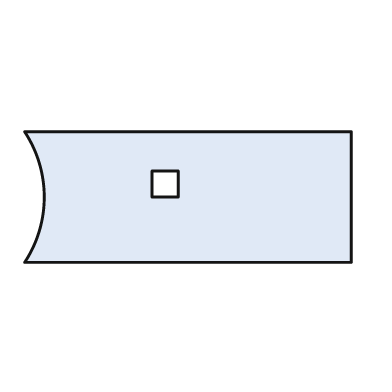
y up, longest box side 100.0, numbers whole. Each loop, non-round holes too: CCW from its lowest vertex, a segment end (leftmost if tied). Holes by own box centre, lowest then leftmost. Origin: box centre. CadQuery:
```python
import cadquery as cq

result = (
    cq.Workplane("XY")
    .moveTo(-50.0, -20.0)
    .lineTo(50.0, -20.0)
    .lineTo(50.0, 20.0)
    .lineTo(-50.0, 20.0)
    .threePointArc((-44.0, 0.0), (-50.0, -20.0))
    .close()
    .moveTo(-11.0, 0.0)
    .lineTo(-3.0, 0.0)
    .lineTo(-3.0, 8.0)
    .lineTo(-11.0, 8.0)
    .close()
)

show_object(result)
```